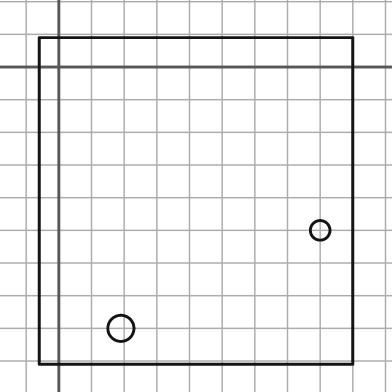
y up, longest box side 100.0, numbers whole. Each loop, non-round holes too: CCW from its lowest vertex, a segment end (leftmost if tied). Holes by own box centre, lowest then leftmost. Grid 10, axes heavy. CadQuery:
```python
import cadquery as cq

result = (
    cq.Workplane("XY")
    .moveTo(-6.0, -91.0)
    .lineTo(90.0, -91.0)
    .lineTo(90.0, 9.0)
    .lineTo(-6.0, 9.0)
    .close()
    .moveTo(19.0, -80.0)
    .circle(4.0)
    .moveTo(80.0, -50.0)
    .circle(3.0)
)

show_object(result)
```